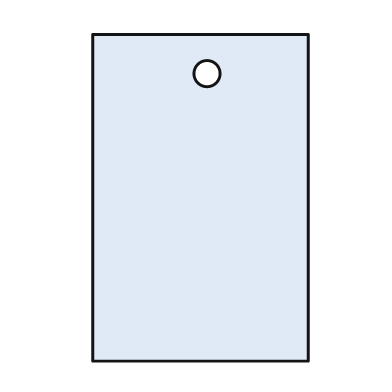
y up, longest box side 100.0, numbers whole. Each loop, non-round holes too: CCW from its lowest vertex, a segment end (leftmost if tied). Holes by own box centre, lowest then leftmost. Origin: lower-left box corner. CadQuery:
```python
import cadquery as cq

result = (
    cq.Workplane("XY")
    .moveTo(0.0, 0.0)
    .lineTo(66.0, 0.0)
    .lineTo(66.0, 100.0)
    .lineTo(0.0, 100.0)
    .close()
    .moveTo(35.0, 88.0)
    .circle(4.0)
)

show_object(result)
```